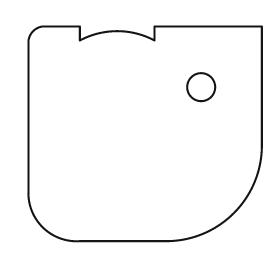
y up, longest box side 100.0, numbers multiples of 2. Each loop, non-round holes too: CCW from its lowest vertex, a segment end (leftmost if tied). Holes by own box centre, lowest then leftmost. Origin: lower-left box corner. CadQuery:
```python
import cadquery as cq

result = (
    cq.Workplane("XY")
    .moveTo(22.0, 0.0)
    .lineTo(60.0, 0.0)
    .threePointArc((88.0, 12.0), (100.0, 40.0))
    .lineTo(100.0, 92.0)
    .lineTo(54.0, 92.0)
    .lineTo(54.0, 86.0)
    .threePointArc((38.0, 90.0), (22.0, 86.0))
    .lineTo(22.0, 92.0)
    .lineTo(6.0, 92.0)
    .threePointArc((2.0, 90.0), (0.0, 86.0))
    .lineTo(0.0, 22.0)
    .threePointArc((6.0, 6.0), (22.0, 0.0))
    .close()
    .moveTo(74.0, 66.0)
    .circle(6.0)
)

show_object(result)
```